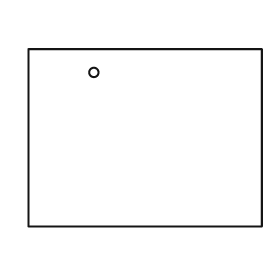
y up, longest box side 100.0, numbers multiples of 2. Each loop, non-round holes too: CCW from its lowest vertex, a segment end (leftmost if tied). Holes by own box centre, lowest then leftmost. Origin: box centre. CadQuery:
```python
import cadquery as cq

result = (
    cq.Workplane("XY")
    .moveTo(-50.0, -38.0)
    .lineTo(50.0, -38.0)
    .lineTo(50.0, 38.0)
    .lineTo(-50.0, 38.0)
    .close()
    .moveTo(-22.0, 28.0)
    .circle(2.0)
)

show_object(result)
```